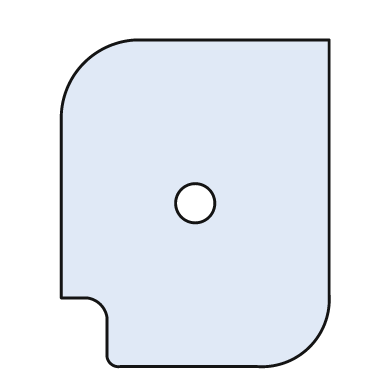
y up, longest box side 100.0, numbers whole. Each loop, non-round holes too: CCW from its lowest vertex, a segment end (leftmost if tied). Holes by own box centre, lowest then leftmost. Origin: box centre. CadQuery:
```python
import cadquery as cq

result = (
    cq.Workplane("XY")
    .moveTo(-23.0, -50.0)
    .lineTo(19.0, -50.0)
    .threePointArc((35.0, -44.0), (41.0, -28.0))
    .lineTo(41.0, 50.0)
    .lineTo(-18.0, 50.0)
    .threePointArc((-34.0, 43.0), (-41.0, 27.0))
    .lineTo(-41.0, -29.0)
    .lineTo(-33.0, -29.0)
    .threePointArc((-29.0, -31.0), (-27.0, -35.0))
    .lineTo(-27.0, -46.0)
    .threePointArc((-26.0, -49.0), (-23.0, -50.0))
    .close()
    .moveTo(0.0, 0.0)
    .circle(6.0)
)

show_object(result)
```